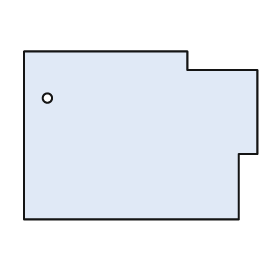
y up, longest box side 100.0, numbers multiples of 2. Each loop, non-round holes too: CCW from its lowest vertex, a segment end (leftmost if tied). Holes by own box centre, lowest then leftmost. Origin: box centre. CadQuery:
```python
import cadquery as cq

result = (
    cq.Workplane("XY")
    .moveTo(-50.0, -36.0)
    .lineTo(42.0, -36.0)
    .lineTo(42.0, -8.0)
    .lineTo(50.0, -8.0)
    .lineTo(50.0, 28.0)
    .lineTo(20.0, 28.0)
    .lineTo(20.0, 36.0)
    .lineTo(-50.0, 36.0)
    .close()
    .moveTo(-40.0, 16.0)
    .circle(2.0)
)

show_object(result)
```